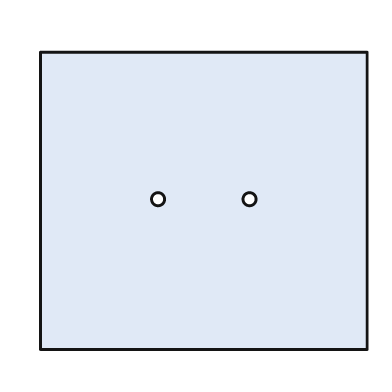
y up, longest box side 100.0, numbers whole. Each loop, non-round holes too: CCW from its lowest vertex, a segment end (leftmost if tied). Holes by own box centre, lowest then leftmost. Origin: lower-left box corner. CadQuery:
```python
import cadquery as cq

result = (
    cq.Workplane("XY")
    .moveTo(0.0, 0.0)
    .lineTo(100.0, 0.0)
    .lineTo(100.0, 91.0)
    .lineTo(0.0, 91.0)
    .close()
    .moveTo(36.0, 46.0)
    .circle(2.0)
    .moveTo(64.0, 46.0)
    .circle(2.0)
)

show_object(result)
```